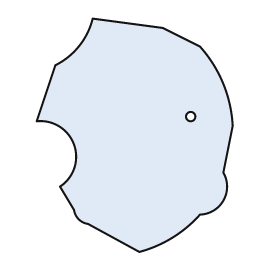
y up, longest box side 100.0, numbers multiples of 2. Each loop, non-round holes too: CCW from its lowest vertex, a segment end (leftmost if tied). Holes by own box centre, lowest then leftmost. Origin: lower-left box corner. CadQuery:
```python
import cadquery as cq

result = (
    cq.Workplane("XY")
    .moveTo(44.0, 0.0)
    .threePointArc((58.0, 6.0), (70.0, 16.0))
    .threePointArc((80.0, 22.0), (80.0, 34.0))
    .lineTo(84.0, 54.0)
    .threePointArc((80.0, 72.0), (70.0, 88.0))
    .lineTo(54.0, 96.0)
    .lineTo(24.0, 100.0)
    .threePointArc((18.0, 88.0), (8.0, 80.0))
    .lineTo(0.0, 56.0)
    .threePointArc((16.0, 46.0), (10.0, 28.0))
    .lineTo(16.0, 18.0)
    .threePointArc((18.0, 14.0), (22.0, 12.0))
    .close()
    .moveTo(66.0, 58.0)
    .circle(2.0)
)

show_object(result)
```